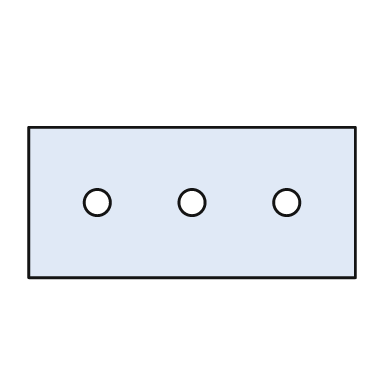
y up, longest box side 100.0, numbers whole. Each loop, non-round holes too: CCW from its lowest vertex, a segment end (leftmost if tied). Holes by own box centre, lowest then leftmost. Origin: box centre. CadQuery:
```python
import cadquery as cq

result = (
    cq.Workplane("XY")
    .moveTo(-50.0, -23.0)
    .lineTo(50.0, -23.0)
    .lineTo(50.0, 23.0)
    .lineTo(-50.0, 23.0)
    .close()
    .moveTo(-29.0, 0.0)
    .circle(4.0)
    .moveTo(0.0, 0.0)
    .circle(4.0)
    .moveTo(29.0, 0.0)
    .circle(4.0)
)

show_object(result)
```